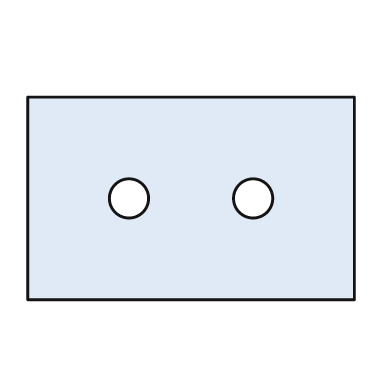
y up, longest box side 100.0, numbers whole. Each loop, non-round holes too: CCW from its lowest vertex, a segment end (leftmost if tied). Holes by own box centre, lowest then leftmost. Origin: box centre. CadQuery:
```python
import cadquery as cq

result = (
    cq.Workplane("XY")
    .moveTo(-50.0, -31.0)
    .lineTo(50.0, -31.0)
    .lineTo(50.0, 31.0)
    .lineTo(-50.0, 31.0)
    .close()
    .moveTo(-19.0, 0.0)
    .circle(6.0)
    .moveTo(19.0, 0.0)
    .circle(6.0)
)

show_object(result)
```